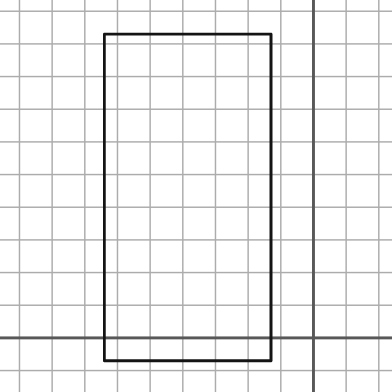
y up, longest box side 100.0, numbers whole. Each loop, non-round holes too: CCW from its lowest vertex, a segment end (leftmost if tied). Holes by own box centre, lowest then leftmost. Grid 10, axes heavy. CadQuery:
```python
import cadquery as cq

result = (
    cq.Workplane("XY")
    .moveTo(-64.0, -7.0)
    .lineTo(-13.0, -7.0)
    .lineTo(-13.0, 93.0)
    .lineTo(-64.0, 93.0)
    .close()
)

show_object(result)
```